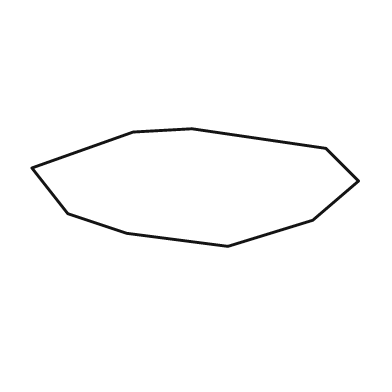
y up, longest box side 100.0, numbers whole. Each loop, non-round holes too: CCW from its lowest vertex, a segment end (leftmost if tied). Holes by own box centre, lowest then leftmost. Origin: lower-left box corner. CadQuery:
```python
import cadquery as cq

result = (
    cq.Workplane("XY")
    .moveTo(60.0, 0.0)
    .lineTo(86.0, 8.0)
    .lineTo(100.0, 20.0)
    .lineTo(90.0, 30.0)
    .lineTo(49.0, 36.0)
    .lineTo(31.0, 35.0)
    .lineTo(0.0, 24.0)
    .lineTo(11.0, 10.0)
    .lineTo(29.0, 4.0)
    .close()
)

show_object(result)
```